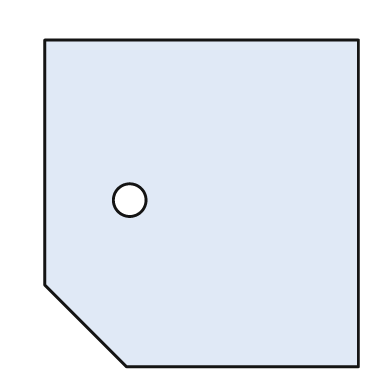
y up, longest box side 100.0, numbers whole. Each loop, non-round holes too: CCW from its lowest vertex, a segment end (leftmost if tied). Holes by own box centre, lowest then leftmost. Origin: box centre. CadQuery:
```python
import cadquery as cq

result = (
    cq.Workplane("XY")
    .moveTo(-23.0, -50.0)
    .lineTo(48.0, -50.0)
    .lineTo(48.0, 50.0)
    .lineTo(-48.0, 50.0)
    .lineTo(-48.0, -25.0)
    .close()
    .moveTo(-22.0, 1.0)
    .circle(5.0)
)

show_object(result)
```